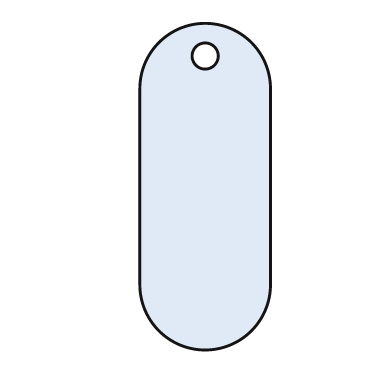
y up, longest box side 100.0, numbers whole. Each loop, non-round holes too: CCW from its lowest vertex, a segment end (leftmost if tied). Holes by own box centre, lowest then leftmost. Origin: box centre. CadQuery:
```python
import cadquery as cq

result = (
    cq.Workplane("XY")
    .moveTo(-20.0, -30.0)
    .threePointArc((0.0, -50.0), (20.0, -30.0))
    .lineTo(20.0, 30.0)
    .threePointArc((0.0, 50.0), (-20.0, 30.0))
    .close()
    .moveTo(0.0, 40.0)
    .circle(4.0)
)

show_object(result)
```